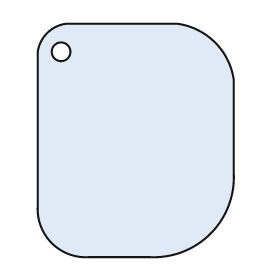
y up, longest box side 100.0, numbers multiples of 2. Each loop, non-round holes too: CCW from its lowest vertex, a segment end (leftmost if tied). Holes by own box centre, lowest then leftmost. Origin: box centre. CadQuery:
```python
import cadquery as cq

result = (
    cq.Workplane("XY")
    .moveTo(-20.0, -50.0)
    .lineTo(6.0, -50.0)
    .threePointArc((32.0, -40.0), (42.0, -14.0))
    .lineTo(42.0, 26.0)
    .threePointArc((34.0, 42.0), (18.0, 50.0))
    .lineTo(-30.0, 50.0)
    .threePointArc((-38.0, 46.0), (-42.0, 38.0))
    .lineTo(-42.0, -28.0)
    .threePointArc((-36.0, -44.0), (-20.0, -50.0))
    .close()
    .moveTo(-32.0, 38.0)
    .circle(4.0)
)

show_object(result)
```